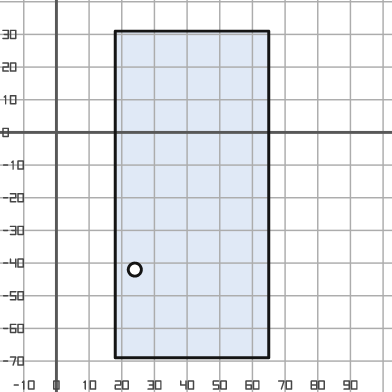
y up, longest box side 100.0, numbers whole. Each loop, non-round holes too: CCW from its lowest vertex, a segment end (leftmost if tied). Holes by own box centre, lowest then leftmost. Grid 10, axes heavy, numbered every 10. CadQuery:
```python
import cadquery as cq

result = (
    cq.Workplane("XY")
    .moveTo(18.0, -69.0)
    .lineTo(65.0, -69.0)
    .lineTo(65.0, 31.0)
    .lineTo(18.0, 31.0)
    .close()
    .moveTo(24.0, -42.0)
    .circle(2.0)
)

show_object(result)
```